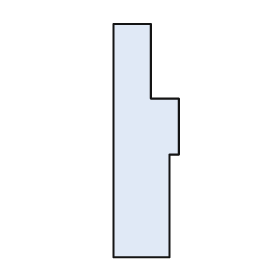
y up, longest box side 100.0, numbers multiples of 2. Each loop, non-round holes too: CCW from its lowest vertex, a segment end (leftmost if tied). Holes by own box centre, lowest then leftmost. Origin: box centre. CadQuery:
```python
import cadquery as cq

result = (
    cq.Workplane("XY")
    .moveTo(-14.0, -50.0)
    .lineTo(10.0, -50.0)
    .lineTo(10.0, -6.0)
    .lineTo(14.0, -6.0)
    .lineTo(14.0, 18.0)
    .lineTo(2.0, 18.0)
    .lineTo(2.0, 50.0)
    .lineTo(-14.0, 50.0)
    .close()
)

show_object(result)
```